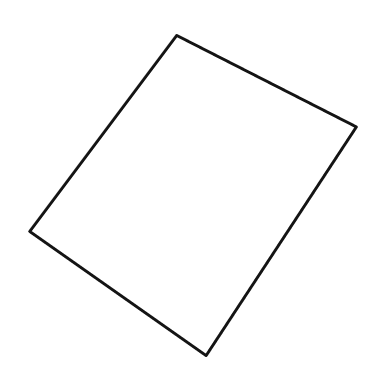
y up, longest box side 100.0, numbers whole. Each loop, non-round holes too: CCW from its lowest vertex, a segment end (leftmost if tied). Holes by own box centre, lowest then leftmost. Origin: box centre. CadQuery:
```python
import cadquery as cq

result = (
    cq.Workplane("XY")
    .moveTo(4.0, -49.0)
    .lineTo(50.0, 21.0)
    .lineTo(-5.0, 49.0)
    .lineTo(-50.0, -11.0)
    .close()
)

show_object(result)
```